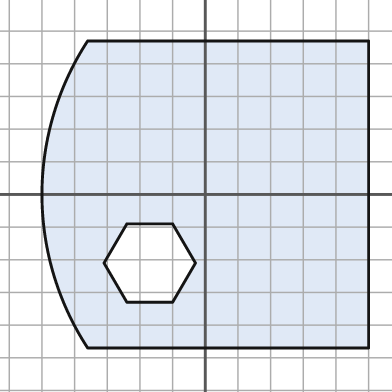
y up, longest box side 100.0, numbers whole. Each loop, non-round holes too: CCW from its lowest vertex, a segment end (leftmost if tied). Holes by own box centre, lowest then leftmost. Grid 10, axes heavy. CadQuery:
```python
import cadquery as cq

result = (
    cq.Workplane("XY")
    .moveTo(-36.0, -47.0)
    .lineTo(50.0, -47.0)
    .lineTo(50.0, 47.0)
    .lineTo(-36.0, 47.0)
    .threePointArc((-50.0, 0.0), (-36.0, -47.0))
    .close()
    .moveTo(-24.0, -33.0)
    .lineTo(-10.0, -33.0)
    .lineTo(-3.0, -21.0)
    .lineTo(-10.0, -9.0)
    .lineTo(-24.0, -9.0)
    .lineTo(-31.0, -21.0)
    .close()
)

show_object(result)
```